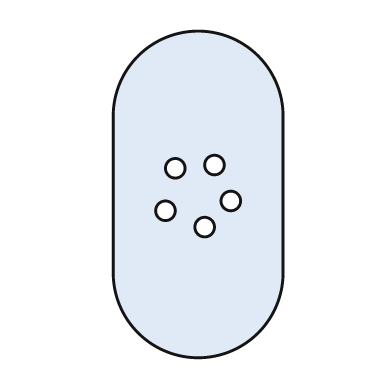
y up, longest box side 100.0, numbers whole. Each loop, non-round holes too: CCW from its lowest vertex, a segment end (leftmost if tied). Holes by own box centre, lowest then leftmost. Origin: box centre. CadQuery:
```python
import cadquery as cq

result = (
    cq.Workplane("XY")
    .moveTo(-26.0, -24.0)
    .threePointArc((0.0, -50.0), (26.0, -24.0))
    .lineTo(26.0, 24.0)
    .threePointArc((0.0, 50.0), (-26.0, 24.0))
    .close()
    .moveTo(2.0, -10.0)
    .circle(3.0)
    .moveTo(-10.0, -5.0)
    .circle(3.0)
    .moveTo(10.0, -2.0)
    .circle(3.0)
    .moveTo(-7.0, 8.0)
    .circle(3.0)
    .moveTo(5.0, 9.0)
    .circle(3.0)
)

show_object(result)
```